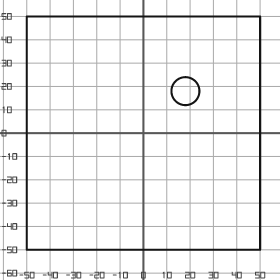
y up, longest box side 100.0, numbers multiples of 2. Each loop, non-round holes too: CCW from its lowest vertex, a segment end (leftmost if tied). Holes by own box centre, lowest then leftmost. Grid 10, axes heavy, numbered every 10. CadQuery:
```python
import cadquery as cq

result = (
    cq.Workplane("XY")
    .moveTo(-50.0, -50.0)
    .lineTo(50.0, -50.0)
    .lineTo(50.0, 50.0)
    .lineTo(-50.0, 50.0)
    .close()
    .moveTo(18.0, 18.0)
    .circle(6.0)
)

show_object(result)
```